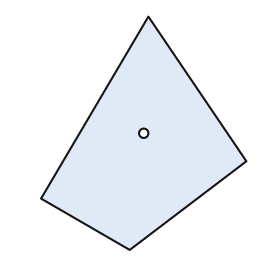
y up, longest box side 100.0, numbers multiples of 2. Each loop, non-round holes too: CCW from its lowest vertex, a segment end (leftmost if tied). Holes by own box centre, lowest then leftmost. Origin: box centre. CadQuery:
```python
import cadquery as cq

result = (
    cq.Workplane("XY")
    .moveTo(-6.0, -50.0)
    .lineTo(44.0, -12.0)
    .lineTo(2.0, 50.0)
    .lineTo(-44.0, -28.0)
    .close()
    .moveTo(0.0, 0.0)
    .circle(2.0)
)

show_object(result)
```